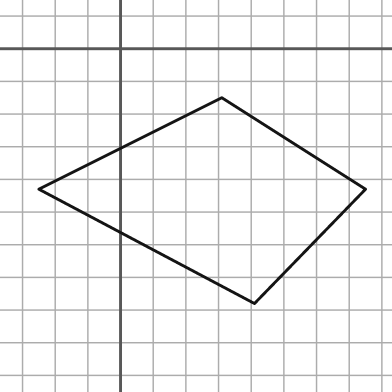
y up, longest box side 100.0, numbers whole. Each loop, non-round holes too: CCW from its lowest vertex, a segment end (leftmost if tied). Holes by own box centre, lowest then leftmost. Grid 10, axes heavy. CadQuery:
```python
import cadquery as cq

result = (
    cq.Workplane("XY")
    .moveTo(41.0, -78.0)
    .lineTo(75.0, -43.0)
    .lineTo(31.0, -15.0)
    .lineTo(-25.0, -43.0)
    .close()
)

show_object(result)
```